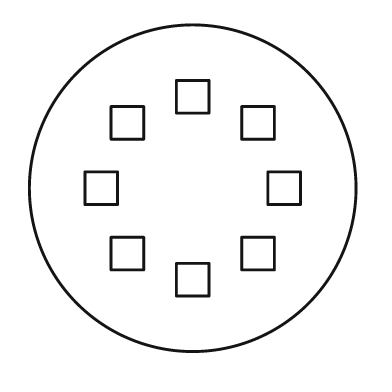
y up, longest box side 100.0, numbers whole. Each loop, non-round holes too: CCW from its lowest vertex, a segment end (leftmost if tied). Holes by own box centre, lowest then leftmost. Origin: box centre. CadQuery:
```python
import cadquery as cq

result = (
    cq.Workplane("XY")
    .moveTo(0.0, 0.0)
    .circle(50.0)
    .moveTo(-5.0, -33.0)
    .lineTo(5.0, -33.0)
    .lineTo(5.0, -23.0)
    .lineTo(-5.0, -23.0)
    .close()
    .moveTo(-25.0, -25.0)
    .lineTo(-15.0, -25.0)
    .lineTo(-15.0, -15.0)
    .lineTo(-25.0, -15.0)
    .close()
    .moveTo(15.0, -25.0)
    .lineTo(25.0, -25.0)
    .lineTo(25.0, -15.0)
    .lineTo(15.0, -15.0)
    .close()
    .moveTo(-33.0, -5.0)
    .lineTo(-23.0, -5.0)
    .lineTo(-23.0, 5.0)
    .lineTo(-33.0, 5.0)
    .close()
    .moveTo(23.0, -5.0)
    .lineTo(33.0, -5.0)
    .lineTo(33.0, 5.0)
    .lineTo(23.0, 5.0)
    .close()
    .moveTo(-25.0, 15.0)
    .lineTo(-15.0, 15.0)
    .lineTo(-15.0, 25.0)
    .lineTo(-25.0, 25.0)
    .close()
    .moveTo(15.0, 15.0)
    .lineTo(25.0, 15.0)
    .lineTo(25.0, 25.0)
    .lineTo(15.0, 25.0)
    .close()
    .moveTo(-5.0, 23.0)
    .lineTo(5.0, 23.0)
    .lineTo(5.0, 33.0)
    .lineTo(-5.0, 33.0)
    .close()
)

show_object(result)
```